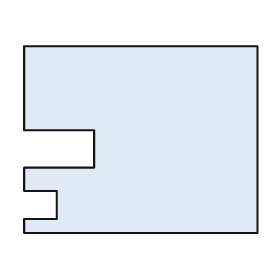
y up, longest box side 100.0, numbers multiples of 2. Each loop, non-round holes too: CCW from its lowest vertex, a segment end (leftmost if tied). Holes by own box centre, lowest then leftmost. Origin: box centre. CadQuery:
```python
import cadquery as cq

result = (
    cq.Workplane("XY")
    .moveTo(-50.0, -40.0)
    .lineTo(50.0, -40.0)
    .lineTo(50.0, 40.0)
    .lineTo(-50.0, 40.0)
    .lineTo(-50.0, 4.0)
    .lineTo(-20.0, 4.0)
    .lineTo(-20.0, -12.0)
    .lineTo(-50.0, -12.0)
    .lineTo(-50.0, -22.0)
    .lineTo(-36.0, -22.0)
    .lineTo(-36.0, -34.0)
    .lineTo(-50.0, -34.0)
    .close()
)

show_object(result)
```